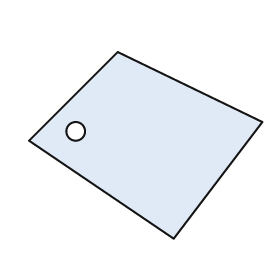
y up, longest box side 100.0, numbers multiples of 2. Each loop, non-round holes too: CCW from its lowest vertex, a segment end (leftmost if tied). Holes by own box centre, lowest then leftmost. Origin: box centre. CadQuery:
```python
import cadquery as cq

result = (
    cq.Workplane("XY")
    .moveTo(12.0, -40.0)
    .lineTo(50.0, 10.0)
    .lineTo(-12.0, 40.0)
    .lineTo(-50.0, 2.0)
    .close()
    .moveTo(-30.0, 6.0)
    .circle(4.0)
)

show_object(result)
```